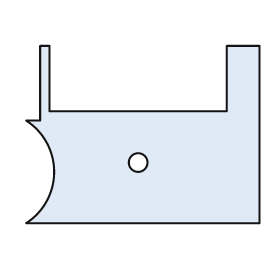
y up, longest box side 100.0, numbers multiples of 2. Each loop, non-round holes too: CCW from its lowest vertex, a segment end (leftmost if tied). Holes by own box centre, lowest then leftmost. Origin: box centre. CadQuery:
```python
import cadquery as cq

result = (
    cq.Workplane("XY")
    .moveTo(-50.0, -38.0)
    .lineTo(50.0, -38.0)
    .lineTo(50.0, 38.0)
    .lineTo(36.0, 38.0)
    .lineTo(36.0, 10.0)
    .lineTo(-40.0, 10.0)
    .lineTo(-40.0, 38.0)
    .lineTo(-44.0, 38.0)
    .lineTo(-44.0, 6.0)
    .lineTo(-50.0, 6.0)
    .threePointArc((-38.0, -16.0), (-50.0, -38.0))
    .close()
    .moveTo(-2.0, -12.0)
    .circle(4.0)
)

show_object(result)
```